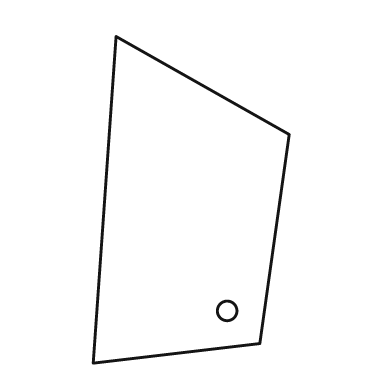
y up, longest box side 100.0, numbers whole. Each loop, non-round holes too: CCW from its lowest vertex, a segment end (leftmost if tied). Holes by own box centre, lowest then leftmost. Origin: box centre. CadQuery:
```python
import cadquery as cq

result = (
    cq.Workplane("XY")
    .moveTo(-30.0, -50.0)
    .lineTo(21.0, -44.0)
    .lineTo(30.0, 20.0)
    .lineTo(-23.0, 50.0)
    .close()
    .moveTo(11.0, -34.0)
    .circle(3.0)
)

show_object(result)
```